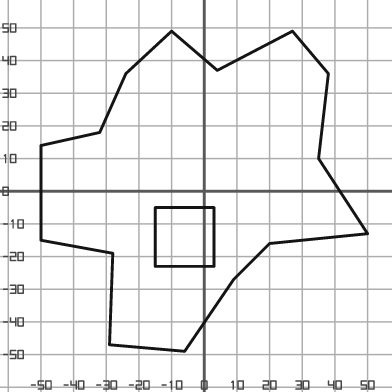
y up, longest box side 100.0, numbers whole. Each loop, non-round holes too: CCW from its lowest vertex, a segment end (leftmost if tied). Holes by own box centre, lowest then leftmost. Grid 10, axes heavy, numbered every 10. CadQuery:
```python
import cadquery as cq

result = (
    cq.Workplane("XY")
    .moveTo(-6.0, -49.0)
    .lineTo(9.0, -27.0)
    .lineTo(20.0, -16.0)
    .lineTo(50.0, -13.0)
    .lineTo(35.0, 10.0)
    .lineTo(38.0, 36.0)
    .lineTo(27.0, 49.0)
    .lineTo(4.0, 37.0)
    .lineTo(-10.0, 49.0)
    .lineTo(-24.0, 36.0)
    .lineTo(-32.0, 18.0)
    .lineTo(-50.0, 14.0)
    .lineTo(-50.0, -15.0)
    .lineTo(-28.0, -19.0)
    .lineTo(-29.0, -47.0)
    .close()
    .moveTo(-15.0, -23.0)
    .lineTo(3.0, -23.0)
    .lineTo(3.0, -5.0)
    .lineTo(-15.0, -5.0)
    .close()
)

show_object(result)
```